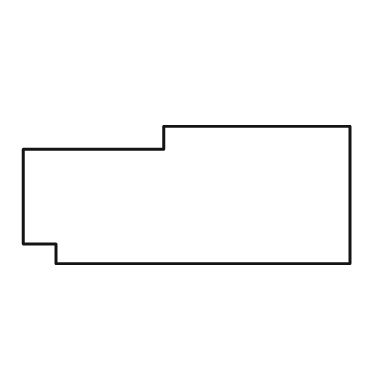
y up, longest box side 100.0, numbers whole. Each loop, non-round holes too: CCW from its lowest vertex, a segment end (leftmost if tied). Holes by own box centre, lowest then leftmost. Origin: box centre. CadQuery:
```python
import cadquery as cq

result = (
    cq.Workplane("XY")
    .moveTo(-40.0, -21.0)
    .lineTo(50.0, -21.0)
    .lineTo(50.0, 21.0)
    .lineTo(-7.0, 21.0)
    .lineTo(-7.0, 14.0)
    .lineTo(-50.0, 14.0)
    .lineTo(-50.0, -15.0)
    .lineTo(-40.0, -15.0)
    .close()
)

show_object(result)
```